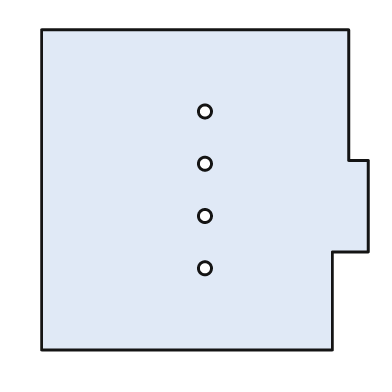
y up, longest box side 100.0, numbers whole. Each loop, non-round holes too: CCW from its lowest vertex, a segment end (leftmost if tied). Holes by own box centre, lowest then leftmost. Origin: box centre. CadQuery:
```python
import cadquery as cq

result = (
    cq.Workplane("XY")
    .moveTo(-50.0, -49.0)
    .lineTo(39.0, -49.0)
    .lineTo(39.0, -19.0)
    .lineTo(50.0, -19.0)
    .lineTo(50.0, 9.0)
    .lineTo(44.0, 9.0)
    .lineTo(44.0, 49.0)
    .lineTo(-50.0, 49.0)
    .close()
    .moveTo(0.0, -24.0)
    .circle(2.0)
    .moveTo(0.0, -8.0)
    .circle(2.0)
    .moveTo(0.0, 8.0)
    .circle(2.0)
    .moveTo(0.0, 24.0)
    .circle(2.0)
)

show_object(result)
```